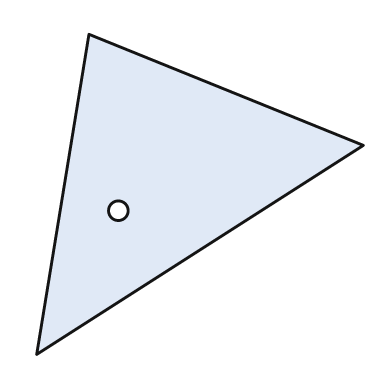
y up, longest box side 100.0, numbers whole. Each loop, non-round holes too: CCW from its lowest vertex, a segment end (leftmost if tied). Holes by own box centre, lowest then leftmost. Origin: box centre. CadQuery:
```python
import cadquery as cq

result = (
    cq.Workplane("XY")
    .moveTo(-50.0, -49.0)
    .lineTo(50.0, 15.0)
    .lineTo(-34.0, 49.0)
    .close()
    .moveTo(-25.0, -5.0)
    .circle(3.0)
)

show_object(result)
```